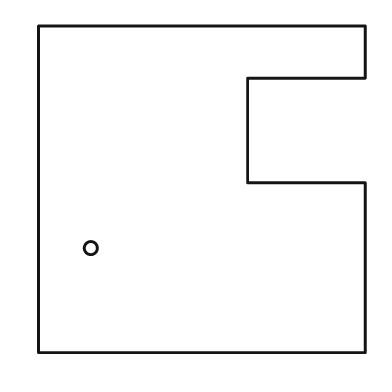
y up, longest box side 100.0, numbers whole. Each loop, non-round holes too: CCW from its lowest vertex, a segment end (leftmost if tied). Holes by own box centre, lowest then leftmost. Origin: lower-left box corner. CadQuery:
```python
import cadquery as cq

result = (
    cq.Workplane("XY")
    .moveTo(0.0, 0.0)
    .lineTo(100.0, 0.0)
    .lineTo(100.0, 52.0)
    .lineTo(64.0, 52.0)
    .lineTo(64.0, 84.0)
    .lineTo(100.0, 84.0)
    .lineTo(100.0, 100.0)
    .lineTo(0.0, 100.0)
    .close()
    .moveTo(16.0, 32.0)
    .circle(2.0)
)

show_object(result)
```